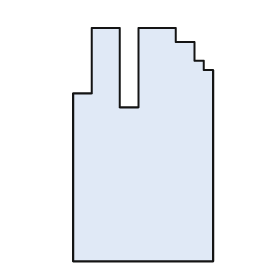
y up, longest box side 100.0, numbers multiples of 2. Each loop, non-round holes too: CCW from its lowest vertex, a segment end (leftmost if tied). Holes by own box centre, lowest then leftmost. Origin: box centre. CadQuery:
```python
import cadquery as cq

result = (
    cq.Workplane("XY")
    .moveTo(-30.0, -50.0)
    .lineTo(30.0, -50.0)
    .lineTo(30.0, 32.0)
    .lineTo(26.0, 32.0)
    .lineTo(26.0, 36.0)
    .lineTo(22.0, 36.0)
    .lineTo(22.0, 44.0)
    .lineTo(14.0, 44.0)
    .lineTo(14.0, 50.0)
    .lineTo(-2.0, 50.0)
    .lineTo(-2.0, 16.0)
    .lineTo(-10.0, 16.0)
    .lineTo(-10.0, 50.0)
    .lineTo(-22.0, 50.0)
    .lineTo(-22.0, 22.0)
    .lineTo(-30.0, 22.0)
    .close()
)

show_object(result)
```